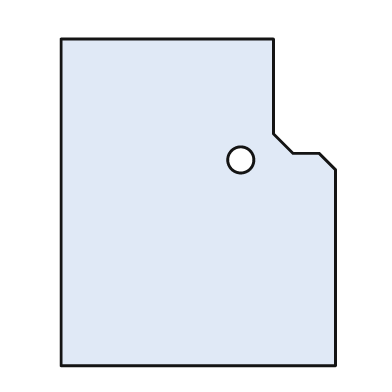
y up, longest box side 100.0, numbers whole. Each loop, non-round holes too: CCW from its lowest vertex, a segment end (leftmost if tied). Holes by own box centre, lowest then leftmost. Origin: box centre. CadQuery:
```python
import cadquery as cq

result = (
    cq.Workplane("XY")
    .moveTo(-42.0, -50.0)
    .lineTo(42.0, -50.0)
    .lineTo(42.0, 10.0)
    .lineTo(37.0, 15.0)
    .lineTo(29.0, 15.0)
    .lineTo(23.0, 21.0)
    .lineTo(23.0, 50.0)
    .lineTo(-42.0, 50.0)
    .close()
    .moveTo(13.0, 13.0)
    .circle(4.0)
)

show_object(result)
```